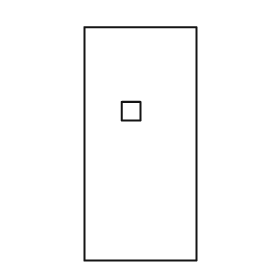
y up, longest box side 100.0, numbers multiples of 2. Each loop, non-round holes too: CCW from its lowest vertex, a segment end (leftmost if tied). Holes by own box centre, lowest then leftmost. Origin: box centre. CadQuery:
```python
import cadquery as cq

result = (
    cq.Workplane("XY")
    .moveTo(-24.0, -50.0)
    .lineTo(24.0, -50.0)
    .lineTo(24.0, 50.0)
    .lineTo(-24.0, 50.0)
    .close()
    .moveTo(-8.0, 10.0)
    .lineTo(0.0, 10.0)
    .lineTo(0.0, 18.0)
    .lineTo(-8.0, 18.0)
    .close()
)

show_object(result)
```